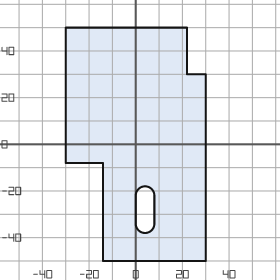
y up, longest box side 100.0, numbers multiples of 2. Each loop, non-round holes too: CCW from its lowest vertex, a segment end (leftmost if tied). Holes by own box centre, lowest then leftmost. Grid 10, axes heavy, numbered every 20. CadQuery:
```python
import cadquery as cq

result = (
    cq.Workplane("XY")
    .moveTo(-14.0, -50.0)
    .lineTo(30.0, -50.0)
    .lineTo(30.0, 30.0)
    .lineTo(22.0, 30.0)
    .lineTo(22.0, 50.0)
    .lineTo(-30.0, 50.0)
    .lineTo(-30.0, -8.0)
    .lineTo(-14.0, -8.0)
    .close()
    .moveTo(0.0, -34.0)
    .threePointArc((4.0, -38.0), (8.0, -34.0))
    .lineTo(8.0, -22.0)
    .threePointArc((4.0, -18.0), (0.0, -22.0))
    .close()
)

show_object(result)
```